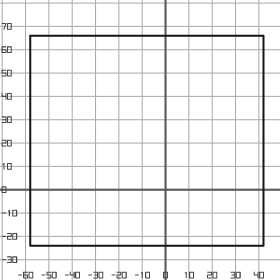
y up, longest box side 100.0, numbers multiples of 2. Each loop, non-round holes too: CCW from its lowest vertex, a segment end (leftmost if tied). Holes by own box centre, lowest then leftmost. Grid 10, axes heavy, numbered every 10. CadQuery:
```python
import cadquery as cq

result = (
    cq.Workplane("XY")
    .moveTo(-58.0, -24.0)
    .lineTo(42.0, -24.0)
    .lineTo(42.0, 66.0)
    .lineTo(-58.0, 66.0)
    .close()
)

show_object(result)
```